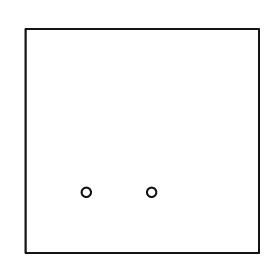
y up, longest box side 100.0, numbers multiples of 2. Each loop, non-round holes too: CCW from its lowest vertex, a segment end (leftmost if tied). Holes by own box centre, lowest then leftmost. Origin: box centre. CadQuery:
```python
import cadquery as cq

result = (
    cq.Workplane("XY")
    .moveTo(-50.0, -48.0)
    .lineTo(50.0, -48.0)
    .lineTo(50.0, 48.0)
    .lineTo(-50.0, 48.0)
    .close()
    .moveTo(-24.0, -22.0)
    .circle(2.0)
    .moveTo(4.0, -22.0)
    .circle(2.0)
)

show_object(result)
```